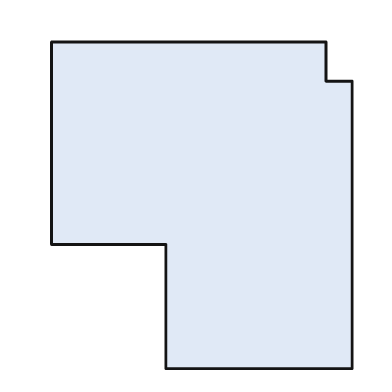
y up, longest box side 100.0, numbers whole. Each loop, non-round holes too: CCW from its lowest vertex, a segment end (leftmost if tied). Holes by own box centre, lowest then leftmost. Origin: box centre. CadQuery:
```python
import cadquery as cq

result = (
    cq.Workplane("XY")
    .moveTo(-11.0, -50.0)
    .lineTo(46.0, -50.0)
    .lineTo(46.0, 38.0)
    .lineTo(38.0, 38.0)
    .lineTo(38.0, 50.0)
    .lineTo(-46.0, 50.0)
    .lineTo(-46.0, -12.0)
    .lineTo(-11.0, -12.0)
    .close()
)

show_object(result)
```